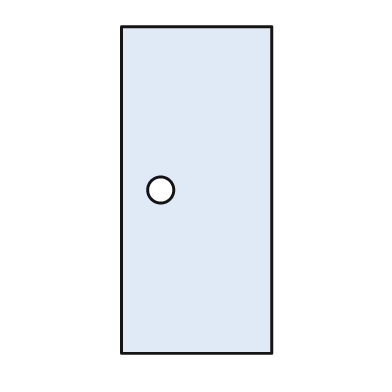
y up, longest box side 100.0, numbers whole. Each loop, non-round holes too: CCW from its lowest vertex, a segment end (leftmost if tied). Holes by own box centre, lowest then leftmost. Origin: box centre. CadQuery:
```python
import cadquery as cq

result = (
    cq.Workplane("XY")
    .moveTo(-23.0, -50.0)
    .lineTo(23.0, -50.0)
    .lineTo(23.0, 50.0)
    .lineTo(-23.0, 50.0)
    .close()
    .moveTo(-11.0, 0.0)
    .circle(4.0)
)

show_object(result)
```